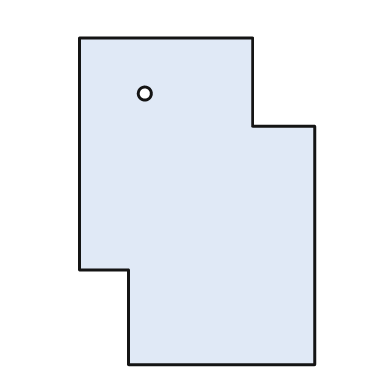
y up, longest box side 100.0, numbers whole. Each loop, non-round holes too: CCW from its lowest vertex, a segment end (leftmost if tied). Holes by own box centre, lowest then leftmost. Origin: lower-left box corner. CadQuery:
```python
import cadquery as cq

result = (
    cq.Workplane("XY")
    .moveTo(15.0, 0.0)
    .lineTo(72.0, 0.0)
    .lineTo(72.0, 73.0)
    .lineTo(53.0, 73.0)
    .lineTo(53.0, 100.0)
    .lineTo(0.0, 100.0)
    .lineTo(0.0, 29.0)
    .lineTo(15.0, 29.0)
    .close()
    .moveTo(20.0, 83.0)
    .circle(2.0)
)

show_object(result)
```